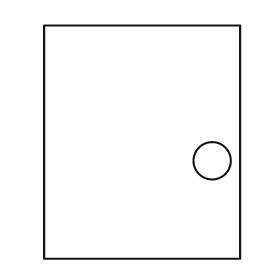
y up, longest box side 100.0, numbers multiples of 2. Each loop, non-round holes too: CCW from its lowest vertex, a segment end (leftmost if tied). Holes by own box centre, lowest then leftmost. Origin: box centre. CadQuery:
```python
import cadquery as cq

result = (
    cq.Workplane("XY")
    .moveTo(-42.0, -50.0)
    .lineTo(42.0, -50.0)
    .lineTo(42.0, 50.0)
    .lineTo(-42.0, 50.0)
    .close()
    .moveTo(30.0, -8.0)
    .circle(8.0)
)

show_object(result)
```